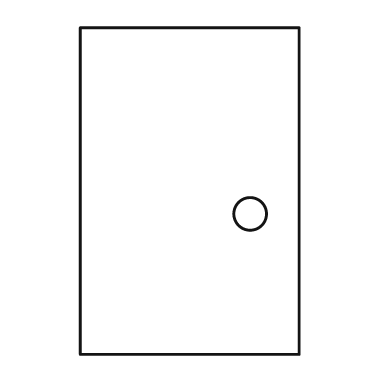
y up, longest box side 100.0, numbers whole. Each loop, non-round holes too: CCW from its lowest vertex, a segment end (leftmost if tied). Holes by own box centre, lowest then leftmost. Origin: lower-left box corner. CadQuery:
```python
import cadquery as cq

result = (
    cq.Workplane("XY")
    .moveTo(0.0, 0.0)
    .lineTo(67.0, 0.0)
    .lineTo(67.0, 100.0)
    .lineTo(0.0, 100.0)
    .close()
    .moveTo(52.0, 43.0)
    .circle(5.0)
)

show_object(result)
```